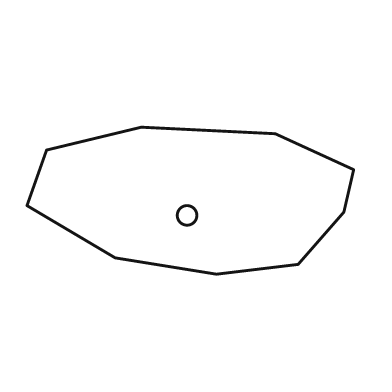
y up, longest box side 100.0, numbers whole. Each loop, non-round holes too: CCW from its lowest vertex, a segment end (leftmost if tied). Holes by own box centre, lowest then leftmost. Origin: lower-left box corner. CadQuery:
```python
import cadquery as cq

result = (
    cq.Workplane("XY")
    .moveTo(58.0, 0.0)
    .lineTo(83.0, 3.0)
    .lineTo(97.0, 19.0)
    .lineTo(100.0, 32.0)
    .lineTo(76.0, 43.0)
    .lineTo(35.0, 45.0)
    .lineTo(6.0, 38.0)
    .lineTo(0.0, 21.0)
    .lineTo(27.0, 5.0)
    .close()
    .moveTo(49.0, 18.0)
    .circle(3.0)
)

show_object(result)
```